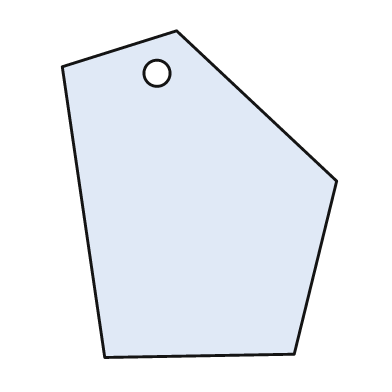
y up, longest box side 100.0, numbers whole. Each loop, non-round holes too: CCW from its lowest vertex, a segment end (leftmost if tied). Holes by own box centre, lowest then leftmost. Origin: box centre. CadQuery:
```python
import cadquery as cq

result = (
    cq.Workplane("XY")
    .moveTo(-29.0, -50.0)
    .lineTo(29.0, -49.0)
    .lineTo(42.0, 4.0)
    .lineTo(-7.0, 50.0)
    .lineTo(-42.0, 39.0)
    .close()
    .moveTo(-13.0, 37.0)
    .circle(4.0)
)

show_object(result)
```